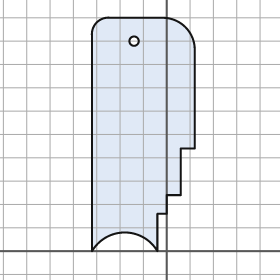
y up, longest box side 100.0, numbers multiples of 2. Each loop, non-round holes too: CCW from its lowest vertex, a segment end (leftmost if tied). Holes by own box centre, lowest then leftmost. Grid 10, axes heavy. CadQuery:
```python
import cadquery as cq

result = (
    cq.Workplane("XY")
    .moveTo(-32.0, 0.0)
    .threePointArc((-18.0, 8.0), (-4.0, 0.0))
    .lineTo(-4.0, 16.0)
    .lineTo(0.0, 16.0)
    .lineTo(0.0, 24.0)
    .lineTo(6.0, 24.0)
    .lineTo(6.0, 44.0)
    .lineTo(12.0, 44.0)
    .lineTo(12.0, 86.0)
    .threePointArc((8.0, 96.0), (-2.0, 100.0))
    .lineTo(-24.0, 100.0)
    .threePointArc((-30.0, 98.0), (-32.0, 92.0))
    .close()
    .moveTo(-14.0, 90.0)
    .circle(2.0)
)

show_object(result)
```